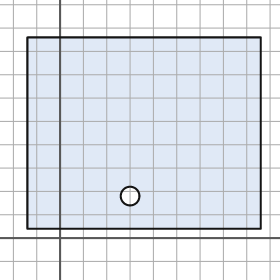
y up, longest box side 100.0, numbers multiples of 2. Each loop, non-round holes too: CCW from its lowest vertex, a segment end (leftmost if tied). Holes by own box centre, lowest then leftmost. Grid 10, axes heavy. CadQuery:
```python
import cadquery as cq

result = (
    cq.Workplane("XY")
    .moveTo(-14.0, 4.0)
    .lineTo(86.0, 4.0)
    .lineTo(86.0, 86.0)
    .lineTo(-14.0, 86.0)
    .close()
    .moveTo(30.0, 18.0)
    .circle(4.0)
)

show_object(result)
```